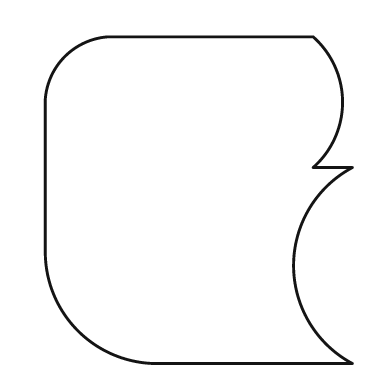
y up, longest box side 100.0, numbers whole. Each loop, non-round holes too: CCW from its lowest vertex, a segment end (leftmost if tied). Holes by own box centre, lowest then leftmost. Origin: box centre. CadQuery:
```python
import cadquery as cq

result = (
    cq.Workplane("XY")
    .moveTo(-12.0, -50.0)
    .lineTo(47.0, -50.0)
    .threePointArc((29.0, -20.0), (47.0, 10.0))
    .lineTo(35.0, 10.0)
    .threePointArc((44.0, 30.0), (35.0, 50.0))
    .lineTo(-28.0, 50.0)
    .threePointArc((-41.0, 44.0), (-47.0, 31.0))
    .lineTo(-47.0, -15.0)
    .threePointArc((-37.0, -40.0), (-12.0, -50.0))
    .close()
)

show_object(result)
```